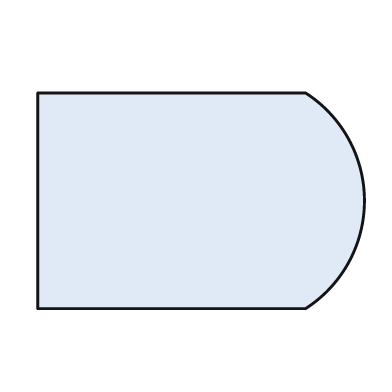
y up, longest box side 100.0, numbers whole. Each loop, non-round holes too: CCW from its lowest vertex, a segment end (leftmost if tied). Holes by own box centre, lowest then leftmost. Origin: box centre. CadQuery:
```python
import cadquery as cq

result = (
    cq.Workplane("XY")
    .moveTo(-50.0, -33.0)
    .lineTo(32.0, -33.0)
    .threePointArc((50.0, 0.0), (32.0, 33.0))
    .lineTo(-50.0, 33.0)
    .close()
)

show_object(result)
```